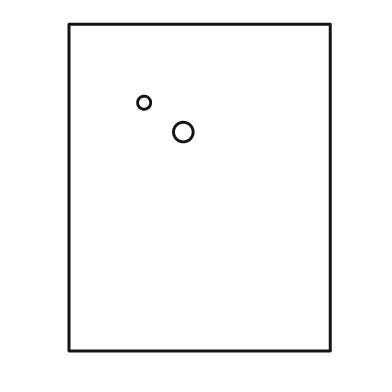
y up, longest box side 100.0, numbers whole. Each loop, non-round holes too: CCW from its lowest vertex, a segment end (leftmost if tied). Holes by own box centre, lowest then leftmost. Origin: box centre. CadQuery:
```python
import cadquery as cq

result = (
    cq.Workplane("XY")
    .moveTo(-40.0, -50.0)
    .lineTo(40.0, -50.0)
    .lineTo(40.0, 50.0)
    .lineTo(-40.0, 50.0)
    .close()
    .moveTo(-5.0, 17.0)
    .circle(3.0)
    .moveTo(-17.0, 26.0)
    .circle(2.0)
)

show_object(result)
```